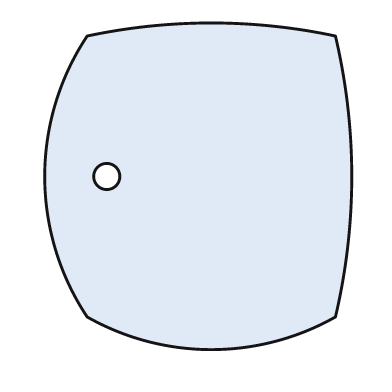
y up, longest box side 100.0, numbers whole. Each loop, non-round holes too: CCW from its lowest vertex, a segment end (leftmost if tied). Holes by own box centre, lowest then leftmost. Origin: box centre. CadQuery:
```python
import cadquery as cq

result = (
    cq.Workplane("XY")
    .moveTo(-34.0, -40.0)
    .threePointArc((4.0, -50.0), (42.0, -40.0))
    .threePointArc((47.0, 3.0), (42.0, 46.0))
    .threePointArc((4.0, 50.0), (-34.0, 46.0))
    .threePointArc((-47.0, 3.0), (-34.0, -40.0))
    .close()
    .moveTo(-28.0, 3.0)
    .circle(4.0)
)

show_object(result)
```